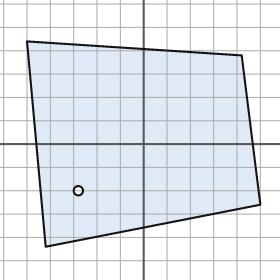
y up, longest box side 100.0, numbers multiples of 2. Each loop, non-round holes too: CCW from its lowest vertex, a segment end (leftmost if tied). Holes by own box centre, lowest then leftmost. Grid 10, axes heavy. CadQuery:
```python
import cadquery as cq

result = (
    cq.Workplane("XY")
    .moveTo(-42.0, -44.0)
    .lineTo(50.0, -26.0)
    .lineTo(42.0, 38.0)
    .lineTo(-50.0, 44.0)
    .close()
    .moveTo(-28.0, -20.0)
    .circle(2.0)
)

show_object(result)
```